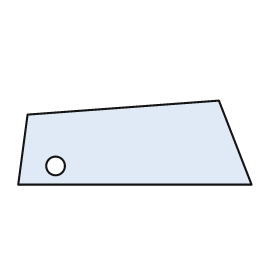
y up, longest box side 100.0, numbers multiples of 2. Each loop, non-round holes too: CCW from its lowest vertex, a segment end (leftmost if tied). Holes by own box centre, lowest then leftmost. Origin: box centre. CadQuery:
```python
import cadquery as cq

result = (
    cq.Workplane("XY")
    .moveTo(-50.0, -18.0)
    .lineTo(50.0, -18.0)
    .lineTo(36.0, 18.0)
    .lineTo(-46.0, 12.0)
    .close()
    .moveTo(-34.0, -10.0)
    .circle(4.0)
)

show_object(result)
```